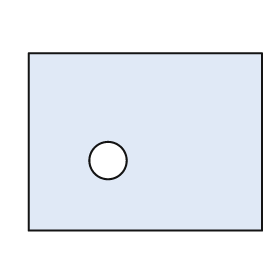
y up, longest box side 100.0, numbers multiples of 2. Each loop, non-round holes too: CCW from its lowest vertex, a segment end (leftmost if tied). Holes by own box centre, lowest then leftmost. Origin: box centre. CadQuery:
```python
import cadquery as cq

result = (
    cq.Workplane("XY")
    .moveTo(-50.0, -38.0)
    .lineTo(50.0, -38.0)
    .lineTo(50.0, 38.0)
    .lineTo(-50.0, 38.0)
    .close()
    .moveTo(-16.0, -8.0)
    .circle(8.0)
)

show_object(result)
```